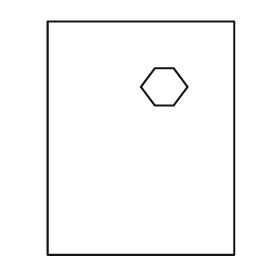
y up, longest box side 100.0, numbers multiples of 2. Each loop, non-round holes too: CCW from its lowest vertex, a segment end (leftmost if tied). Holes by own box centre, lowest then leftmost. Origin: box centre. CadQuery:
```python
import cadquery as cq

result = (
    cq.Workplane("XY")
    .moveTo(-40.0, -50.0)
    .lineTo(40.0, -50.0)
    .lineTo(40.0, 50.0)
    .lineTo(-40.0, 50.0)
    .close()
    .moveTo(6.0, 14.0)
    .lineTo(14.0, 14.0)
    .lineTo(20.0, 22.0)
    .lineTo(14.0, 30.0)
    .lineTo(6.0, 30.0)
    .lineTo(0.0, 22.0)
    .close()
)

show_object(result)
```